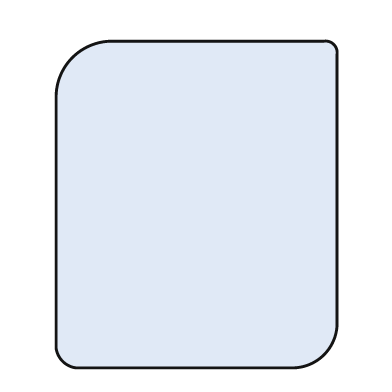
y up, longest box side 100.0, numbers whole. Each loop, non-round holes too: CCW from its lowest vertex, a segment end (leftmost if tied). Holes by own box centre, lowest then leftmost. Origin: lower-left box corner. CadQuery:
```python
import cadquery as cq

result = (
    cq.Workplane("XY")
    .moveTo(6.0, 0.0)
    .lineTo(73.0, 0.0)
    .threePointArc((82.0, 4.0), (86.0, 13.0))
    .lineTo(86.0, 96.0)
    .threePointArc((85.0, 99.0), (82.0, 100.0))
    .lineTo(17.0, 100.0)
    .threePointArc((5.0, 95.0), (0.0, 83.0))
    .lineTo(0.0, 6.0)
    .threePointArc((2.0, 2.0), (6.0, 0.0))
    .close()
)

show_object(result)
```